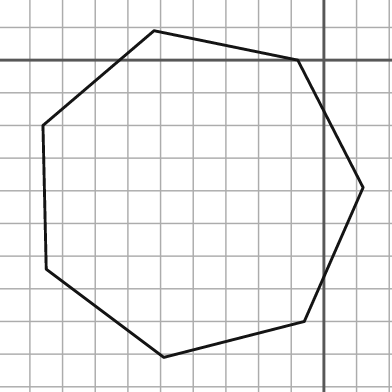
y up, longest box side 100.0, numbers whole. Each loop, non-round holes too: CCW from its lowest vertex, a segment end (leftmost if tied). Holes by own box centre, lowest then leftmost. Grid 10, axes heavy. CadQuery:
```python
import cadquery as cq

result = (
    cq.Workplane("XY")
    .moveTo(-49.0, -91.0)
    .lineTo(-6.0, -80.0)
    .lineTo(12.0, -39.0)
    .lineTo(-8.0, 0.0)
    .lineTo(-52.0, 9.0)
    .lineTo(-86.0, -20.0)
    .lineTo(-85.0, -64.0)
    .close()
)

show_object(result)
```